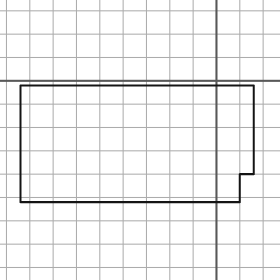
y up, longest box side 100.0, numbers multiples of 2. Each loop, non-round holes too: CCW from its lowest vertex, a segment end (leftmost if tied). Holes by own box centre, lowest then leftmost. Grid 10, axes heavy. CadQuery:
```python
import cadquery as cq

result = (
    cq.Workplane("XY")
    .moveTo(-84.0, -52.0)
    .lineTo(10.0, -52.0)
    .lineTo(10.0, -40.0)
    .lineTo(16.0, -40.0)
    .lineTo(16.0, -2.0)
    .lineTo(-84.0, -2.0)
    .close()
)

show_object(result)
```